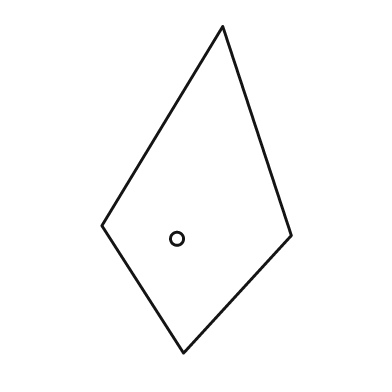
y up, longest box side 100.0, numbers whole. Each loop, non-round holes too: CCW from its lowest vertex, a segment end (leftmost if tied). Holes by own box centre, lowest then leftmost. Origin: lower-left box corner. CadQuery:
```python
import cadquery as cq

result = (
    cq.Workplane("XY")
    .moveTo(25.0, 0.0)
    .lineTo(58.0, 36.0)
    .lineTo(37.0, 100.0)
    .lineTo(0.0, 39.0)
    .close()
    .moveTo(23.0, 35.0)
    .circle(2.0)
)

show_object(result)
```